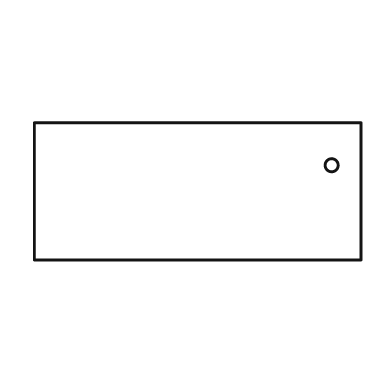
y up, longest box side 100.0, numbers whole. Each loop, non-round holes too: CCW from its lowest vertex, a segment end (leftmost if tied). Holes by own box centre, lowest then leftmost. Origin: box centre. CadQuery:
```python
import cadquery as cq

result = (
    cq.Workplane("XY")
    .moveTo(-50.0, -21.0)
    .lineTo(50.0, -21.0)
    .lineTo(50.0, 21.0)
    .lineTo(-50.0, 21.0)
    .close()
    .moveTo(41.0, 8.0)
    .circle(2.0)
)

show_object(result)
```